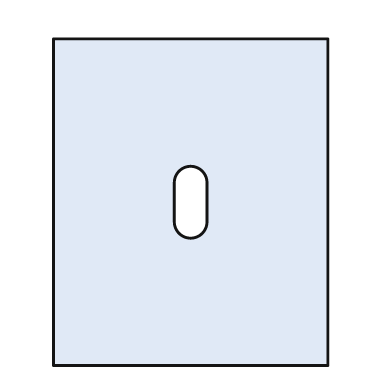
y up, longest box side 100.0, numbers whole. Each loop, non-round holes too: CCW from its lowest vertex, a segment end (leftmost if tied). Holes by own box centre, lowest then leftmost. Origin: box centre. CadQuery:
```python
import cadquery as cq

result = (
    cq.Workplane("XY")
    .moveTo(-42.0, -50.0)
    .lineTo(42.0, -50.0)
    .lineTo(42.0, 50.0)
    .lineTo(-42.0, 50.0)
    .close()
    .moveTo(-5.0, -6.0)
    .threePointArc((0.0, -11.0), (5.0, -6.0))
    .lineTo(5.0, 6.0)
    .threePointArc((0.0, 11.0), (-5.0, 6.0))
    .close()
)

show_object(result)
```